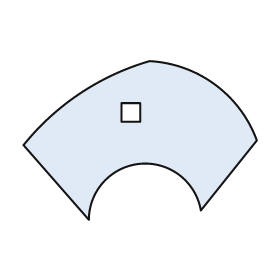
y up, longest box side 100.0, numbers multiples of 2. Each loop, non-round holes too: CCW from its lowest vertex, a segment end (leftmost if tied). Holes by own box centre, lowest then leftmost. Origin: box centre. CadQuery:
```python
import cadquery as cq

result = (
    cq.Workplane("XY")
    .moveTo(-22.0, -34.0)
    .threePointArc((0.0, -10.0), (26.0, -30.0))
    .lineTo(50.0, 0.0)
    .threePointArc((32.0, 24.0), (4.0, 34.0))
    .threePointArc((-26.0, 20.0), (-50.0, -2.0))
    .close()
    .moveTo(-8.0, 8.0)
    .lineTo(0.0, 8.0)
    .lineTo(0.0, 16.0)
    .lineTo(-8.0, 16.0)
    .close()
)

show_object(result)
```